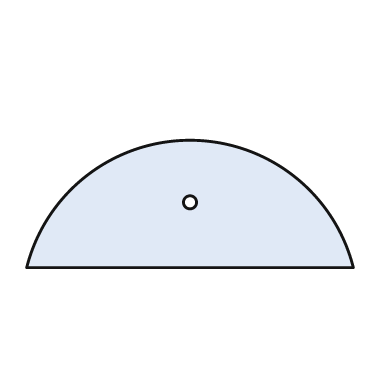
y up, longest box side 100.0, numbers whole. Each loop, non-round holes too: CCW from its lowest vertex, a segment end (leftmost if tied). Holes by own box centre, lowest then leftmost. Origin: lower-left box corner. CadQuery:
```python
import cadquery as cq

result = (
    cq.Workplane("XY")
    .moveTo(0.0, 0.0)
    .lineTo(100.0, 0.0)
    .threePointArc((50.0, 39.0), (0.0, 0.0))
    .close()
    .moveTo(50.0, 20.0)
    .circle(2.0)
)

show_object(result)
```